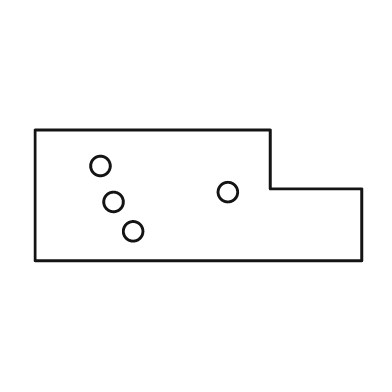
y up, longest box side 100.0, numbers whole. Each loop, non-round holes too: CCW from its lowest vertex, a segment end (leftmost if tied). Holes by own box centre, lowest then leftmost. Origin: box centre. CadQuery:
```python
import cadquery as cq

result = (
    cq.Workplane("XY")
    .moveTo(-50.0, -20.0)
    .lineTo(50.0, -20.0)
    .lineTo(50.0, 2.0)
    .lineTo(22.0, 2.0)
    .lineTo(22.0, 20.0)
    .lineTo(-50.0, 20.0)
    .close()
    .moveTo(-20.0, -11.0)
    .circle(3.0)
    .moveTo(-26.0, -2.0)
    .circle(3.0)
    .moveTo(9.0, 1.0)
    .circle(3.0)
    .moveTo(-30.0, 9.0)
    .circle(3.0)
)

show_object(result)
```